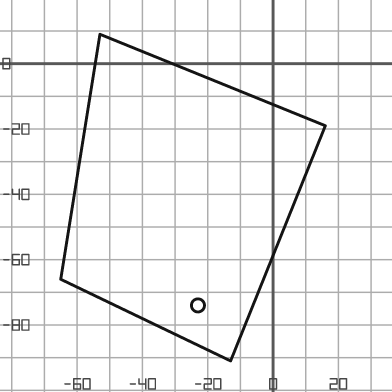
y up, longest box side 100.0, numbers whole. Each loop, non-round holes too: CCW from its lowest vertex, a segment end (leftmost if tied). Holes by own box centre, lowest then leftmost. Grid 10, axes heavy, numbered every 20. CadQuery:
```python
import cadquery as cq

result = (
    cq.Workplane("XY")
    .moveTo(-13.0, -91.0)
    .lineTo(16.0, -19.0)
    .lineTo(-53.0, 9.0)
    .lineTo(-65.0, -66.0)
    .close()
    .moveTo(-23.0, -74.0)
    .circle(2.0)
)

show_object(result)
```